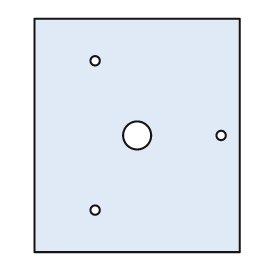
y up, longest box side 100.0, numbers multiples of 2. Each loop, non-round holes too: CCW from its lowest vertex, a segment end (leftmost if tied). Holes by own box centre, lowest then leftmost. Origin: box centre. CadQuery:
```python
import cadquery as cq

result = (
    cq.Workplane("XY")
    .moveTo(-44.0, -50.0)
    .lineTo(44.0, -50.0)
    .lineTo(44.0, 50.0)
    .lineTo(-44.0, 50.0)
    .close()
    .moveTo(-18.0, -32.0)
    .circle(2.0)
    .moveTo(0.0, 0.0)
    .circle(6.0)
    .moveTo(36.0, 0.0)
    .circle(2.0)
    .moveTo(-18.0, 32.0)
    .circle(2.0)
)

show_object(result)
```